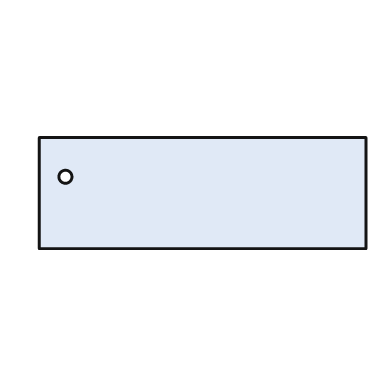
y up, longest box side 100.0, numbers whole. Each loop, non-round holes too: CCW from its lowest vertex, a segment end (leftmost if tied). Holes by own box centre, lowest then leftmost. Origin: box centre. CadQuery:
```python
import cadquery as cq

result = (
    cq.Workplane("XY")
    .moveTo(-50.0, -17.0)
    .lineTo(50.0, -17.0)
    .lineTo(50.0, 17.0)
    .lineTo(-50.0, 17.0)
    .close()
    .moveTo(-42.0, 5.0)
    .circle(2.0)
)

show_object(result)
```